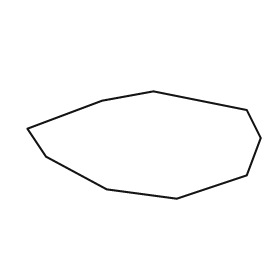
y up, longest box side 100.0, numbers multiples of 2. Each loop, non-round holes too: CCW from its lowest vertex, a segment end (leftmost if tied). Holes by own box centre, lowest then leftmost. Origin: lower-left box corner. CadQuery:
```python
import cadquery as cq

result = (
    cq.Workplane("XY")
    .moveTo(64.0, 0.0)
    .lineTo(94.0, 10.0)
    .lineTo(100.0, 26.0)
    .lineTo(94.0, 38.0)
    .lineTo(54.0, 46.0)
    .lineTo(32.0, 42.0)
    .lineTo(0.0, 30.0)
    .lineTo(8.0, 18.0)
    .lineTo(34.0, 4.0)
    .close()
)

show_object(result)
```